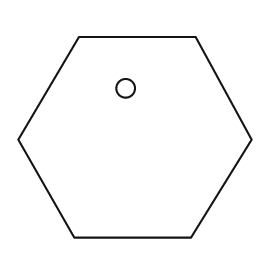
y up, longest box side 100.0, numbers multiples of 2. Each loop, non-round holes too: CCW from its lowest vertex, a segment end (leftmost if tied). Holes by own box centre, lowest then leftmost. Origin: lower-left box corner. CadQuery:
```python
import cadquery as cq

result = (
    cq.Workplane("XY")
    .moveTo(24.0, 0.0)
    .lineTo(74.0, 0.0)
    .lineTo(100.0, 42.0)
    .lineTo(76.0, 86.0)
    .lineTo(26.0, 86.0)
    .lineTo(0.0, 42.0)
    .close()
    .moveTo(46.0, 64.0)
    .circle(4.0)
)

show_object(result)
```